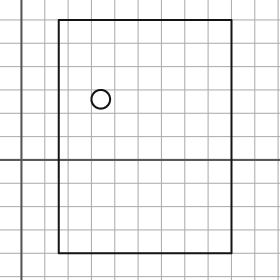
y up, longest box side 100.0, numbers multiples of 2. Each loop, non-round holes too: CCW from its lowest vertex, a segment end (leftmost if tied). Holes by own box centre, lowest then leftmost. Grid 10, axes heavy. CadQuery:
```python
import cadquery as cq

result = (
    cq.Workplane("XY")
    .moveTo(16.0, -40.0)
    .lineTo(90.0, -40.0)
    .lineTo(90.0, 60.0)
    .lineTo(16.0, 60.0)
    .close()
    .moveTo(34.0, 26.0)
    .circle(4.0)
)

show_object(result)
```